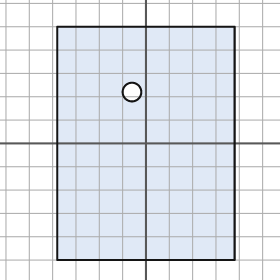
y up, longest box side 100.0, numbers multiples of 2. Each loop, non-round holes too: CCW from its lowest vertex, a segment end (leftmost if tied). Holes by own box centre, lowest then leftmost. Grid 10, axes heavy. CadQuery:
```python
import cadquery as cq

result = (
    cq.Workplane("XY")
    .moveTo(-38.0, -50.0)
    .lineTo(38.0, -50.0)
    .lineTo(38.0, 50.0)
    .lineTo(-38.0, 50.0)
    .close()
    .moveTo(-6.0, 22.0)
    .circle(4.0)
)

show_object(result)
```